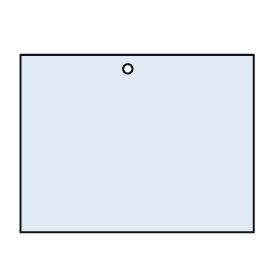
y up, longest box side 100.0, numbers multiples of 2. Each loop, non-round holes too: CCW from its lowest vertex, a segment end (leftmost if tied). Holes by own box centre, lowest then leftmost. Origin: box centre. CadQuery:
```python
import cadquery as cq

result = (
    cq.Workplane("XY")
    .moveTo(-50.0, -38.0)
    .lineTo(50.0, -38.0)
    .lineTo(50.0, 38.0)
    .lineTo(-50.0, 38.0)
    .close()
    .moveTo(-4.0, 32.0)
    .circle(2.0)
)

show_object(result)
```